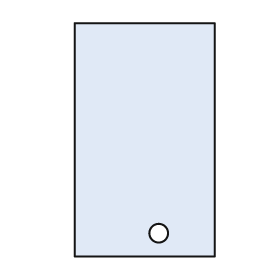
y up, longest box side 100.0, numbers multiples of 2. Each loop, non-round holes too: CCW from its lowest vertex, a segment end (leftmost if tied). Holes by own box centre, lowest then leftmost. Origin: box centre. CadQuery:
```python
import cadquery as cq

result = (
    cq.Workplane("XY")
    .moveTo(-30.0, -50.0)
    .lineTo(30.0, -50.0)
    .lineTo(30.0, 50.0)
    .lineTo(-30.0, 50.0)
    .close()
    .moveTo(6.0, -40.0)
    .circle(4.0)
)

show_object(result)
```